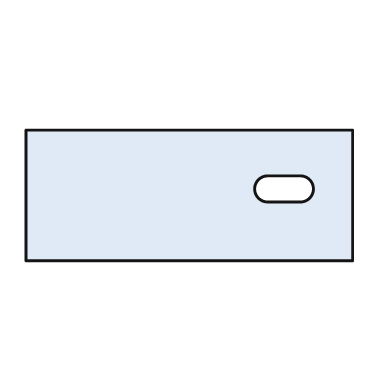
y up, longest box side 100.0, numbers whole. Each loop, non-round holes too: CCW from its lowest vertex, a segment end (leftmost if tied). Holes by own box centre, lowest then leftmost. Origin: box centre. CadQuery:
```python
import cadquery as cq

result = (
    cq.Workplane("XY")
    .moveTo(-50.0, -20.0)
    .lineTo(50.0, -20.0)
    .lineTo(50.0, 20.0)
    .lineTo(-50.0, 20.0)
    .close()
    .moveTo(24.0, -2.0)
    .lineTo(34.0, -2.0)
    .threePointArc((38.0, 2.0), (34.0, 6.0))
    .lineTo(24.0, 6.0)
    .threePointArc((20.0, 2.0), (24.0, -2.0))
    .close()
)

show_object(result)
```